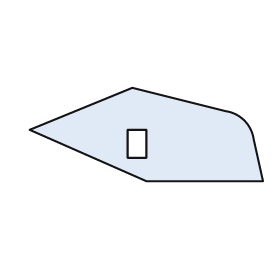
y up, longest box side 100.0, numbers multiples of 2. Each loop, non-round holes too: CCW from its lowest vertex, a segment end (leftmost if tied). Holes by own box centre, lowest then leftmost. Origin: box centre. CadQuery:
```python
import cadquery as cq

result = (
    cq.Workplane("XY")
    .moveTo(0.0, -20.0)
    .lineTo(50.0, -20.0)
    .lineTo(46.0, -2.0)
    .threePointArc((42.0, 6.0), (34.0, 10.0))
    .lineTo(-6.0, 20.0)
    .lineTo(-50.0, 2.0)
    .close()
    .moveTo(-8.0, -10.0)
    .lineTo(0.0, -10.0)
    .lineTo(0.0, 2.0)
    .lineTo(-8.0, 2.0)
    .close()
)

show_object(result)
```